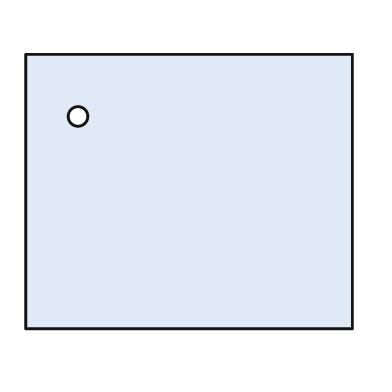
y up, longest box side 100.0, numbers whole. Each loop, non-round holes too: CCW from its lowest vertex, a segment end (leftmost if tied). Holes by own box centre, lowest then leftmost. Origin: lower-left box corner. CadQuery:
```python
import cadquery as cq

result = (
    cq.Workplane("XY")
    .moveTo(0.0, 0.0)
    .lineTo(100.0, 0.0)
    .lineTo(100.0, 84.0)
    .lineTo(0.0, 84.0)
    .close()
    .moveTo(16.0, 65.0)
    .circle(3.0)
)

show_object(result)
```